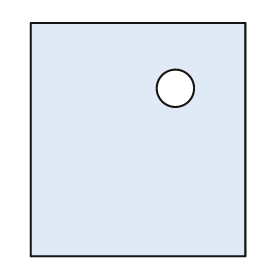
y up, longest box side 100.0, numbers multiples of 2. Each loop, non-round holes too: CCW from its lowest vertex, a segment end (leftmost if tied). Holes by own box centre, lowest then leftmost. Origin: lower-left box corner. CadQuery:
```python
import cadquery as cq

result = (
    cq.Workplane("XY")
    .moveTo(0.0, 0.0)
    .lineTo(92.0, 0.0)
    .lineTo(92.0, 100.0)
    .lineTo(0.0, 100.0)
    .close()
    .moveTo(62.0, 72.0)
    .circle(8.0)
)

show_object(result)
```